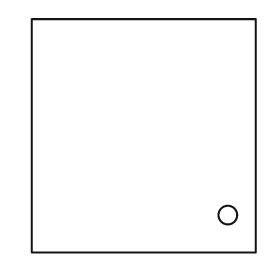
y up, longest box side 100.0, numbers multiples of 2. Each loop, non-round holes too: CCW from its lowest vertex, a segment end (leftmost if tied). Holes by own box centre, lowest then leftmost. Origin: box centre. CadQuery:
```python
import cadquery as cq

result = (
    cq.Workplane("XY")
    .moveTo(-48.0, -50.0)
    .lineTo(48.0, -50.0)
    .lineTo(48.0, 50.0)
    .lineTo(-48.0, 50.0)
    .close()
    .moveTo(36.0, -34.0)
    .circle(4.0)
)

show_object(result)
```